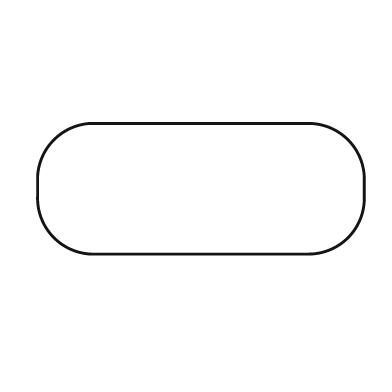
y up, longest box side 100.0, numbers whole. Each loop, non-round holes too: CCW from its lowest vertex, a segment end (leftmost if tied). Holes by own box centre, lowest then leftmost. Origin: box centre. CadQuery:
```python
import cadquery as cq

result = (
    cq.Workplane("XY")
    .moveTo(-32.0, -20.0)
    .lineTo(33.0, -20.0)
    .threePointArc((45.0, -15.0), (50.0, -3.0))
    .lineTo(50.0, 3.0)
    .threePointArc((45.0, 15.0), (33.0, 20.0))
    .lineTo(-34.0, 20.0)
    .threePointArc((-45.0, 15.0), (-50.0, 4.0))
    .lineTo(-50.0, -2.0)
    .threePointArc((-45.0, -15.0), (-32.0, -20.0))
    .close()
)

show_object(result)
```